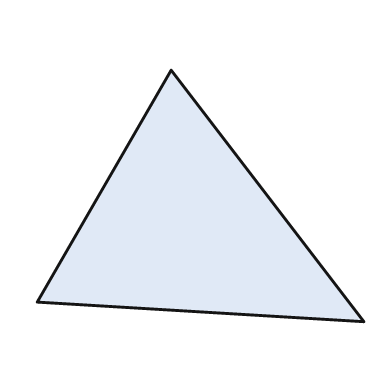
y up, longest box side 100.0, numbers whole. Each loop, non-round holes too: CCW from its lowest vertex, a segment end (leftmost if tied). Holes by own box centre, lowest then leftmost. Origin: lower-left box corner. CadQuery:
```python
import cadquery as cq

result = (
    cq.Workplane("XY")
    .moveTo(100.0, 0.0)
    .lineTo(41.0, 77.0)
    .lineTo(0.0, 6.0)
    .close()
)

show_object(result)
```